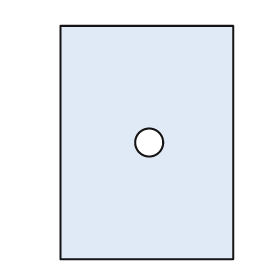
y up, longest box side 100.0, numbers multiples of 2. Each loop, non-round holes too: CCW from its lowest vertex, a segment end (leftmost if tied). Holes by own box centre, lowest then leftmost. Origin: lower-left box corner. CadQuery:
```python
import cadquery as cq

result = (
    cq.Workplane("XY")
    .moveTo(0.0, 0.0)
    .lineTo(74.0, 0.0)
    .lineTo(74.0, 100.0)
    .lineTo(0.0, 100.0)
    .close()
    .moveTo(38.0, 50.0)
    .circle(6.0)
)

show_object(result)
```